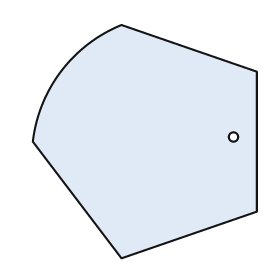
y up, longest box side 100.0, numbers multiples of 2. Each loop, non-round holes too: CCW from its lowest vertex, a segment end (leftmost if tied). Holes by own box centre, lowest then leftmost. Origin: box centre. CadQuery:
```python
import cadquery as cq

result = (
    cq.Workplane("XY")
    .moveTo(-10.0, -50.0)
    .lineTo(48.0, -30.0)
    .lineTo(48.0, 30.0)
    .lineTo(-10.0, 50.0)
    .threePointArc((-36.0, 30.0), (-48.0, 0.0))
    .close()
    .moveTo(38.0, 2.0)
    .circle(2.0)
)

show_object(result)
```